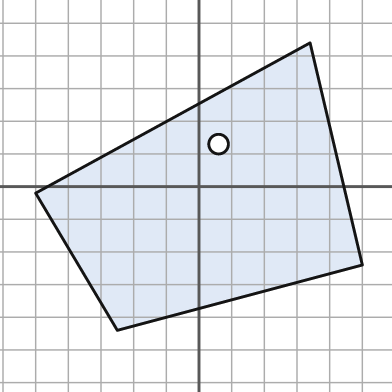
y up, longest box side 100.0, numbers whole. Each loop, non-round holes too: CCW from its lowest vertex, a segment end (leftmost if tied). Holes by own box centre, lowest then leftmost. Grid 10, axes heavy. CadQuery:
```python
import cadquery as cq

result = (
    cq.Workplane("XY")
    .moveTo(-25.0, -44.0)
    .lineTo(50.0, -24.0)
    .lineTo(34.0, 44.0)
    .lineTo(-50.0, -2.0)
    .close()
    .moveTo(6.0, 13.0)
    .circle(3.0)
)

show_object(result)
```